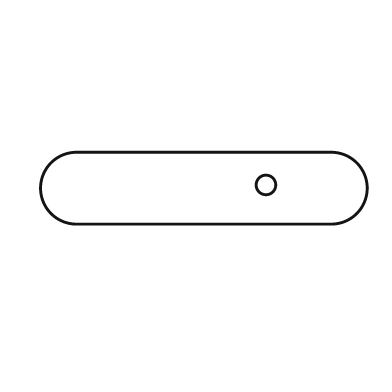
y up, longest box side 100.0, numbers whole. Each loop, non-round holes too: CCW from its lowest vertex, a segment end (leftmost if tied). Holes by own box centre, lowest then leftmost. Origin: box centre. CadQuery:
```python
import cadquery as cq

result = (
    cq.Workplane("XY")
    .moveTo(-39.0, -11.0)
    .lineTo(39.0, -11.0)
    .threePointArc((50.0, 0.0), (39.0, 11.0))
    .lineTo(-39.0, 11.0)
    .threePointArc((-50.0, 0.0), (-39.0, -11.0))
    .close()
    .moveTo(19.0, 1.0)
    .circle(3.0)
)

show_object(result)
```